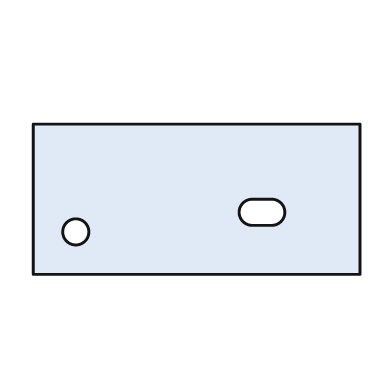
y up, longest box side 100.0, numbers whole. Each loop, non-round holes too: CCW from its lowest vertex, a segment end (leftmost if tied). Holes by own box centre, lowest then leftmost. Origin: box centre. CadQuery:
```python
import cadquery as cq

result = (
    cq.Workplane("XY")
    .moveTo(-50.0, -23.0)
    .lineTo(50.0, -23.0)
    .lineTo(50.0, 23.0)
    .lineTo(-50.0, 23.0)
    .close()
    .moveTo(-37.0, -10.0)
    .circle(4.0)
    .moveTo(17.0, -8.0)
    .lineTo(23.0, -8.0)
    .threePointArc((27.0, -4.0), (23.0, 0.0))
    .lineTo(17.0, 0.0)
    .threePointArc((13.0, -4.0), (17.0, -8.0))
    .close()
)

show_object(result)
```